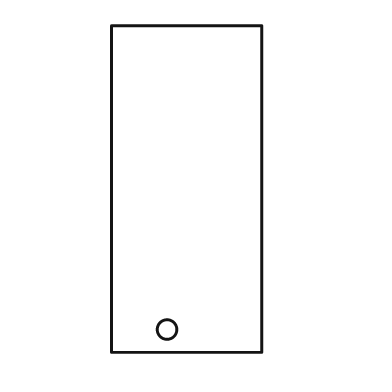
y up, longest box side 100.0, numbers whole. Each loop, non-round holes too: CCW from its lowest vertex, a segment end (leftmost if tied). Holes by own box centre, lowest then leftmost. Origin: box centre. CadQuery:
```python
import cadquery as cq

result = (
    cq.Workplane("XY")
    .moveTo(-23.0, -50.0)
    .lineTo(23.0, -50.0)
    .lineTo(23.0, 50.0)
    .lineTo(-23.0, 50.0)
    .close()
    .moveTo(-6.0, -43.0)
    .circle(3.0)
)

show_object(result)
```